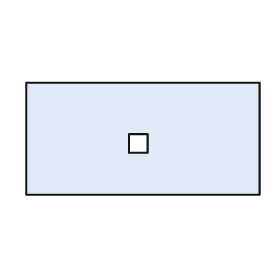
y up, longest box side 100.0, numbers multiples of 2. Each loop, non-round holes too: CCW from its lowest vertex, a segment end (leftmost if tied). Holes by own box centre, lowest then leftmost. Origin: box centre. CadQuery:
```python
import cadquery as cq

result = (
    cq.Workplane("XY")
    .moveTo(-50.0, -24.0)
    .lineTo(50.0, -24.0)
    .lineTo(50.0, 24.0)
    .lineTo(-50.0, 24.0)
    .close()
    .moveTo(-6.0, -6.0)
    .lineTo(2.0, -6.0)
    .lineTo(2.0, 2.0)
    .lineTo(-6.0, 2.0)
    .close()
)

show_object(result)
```